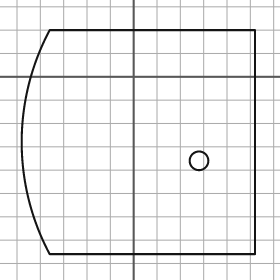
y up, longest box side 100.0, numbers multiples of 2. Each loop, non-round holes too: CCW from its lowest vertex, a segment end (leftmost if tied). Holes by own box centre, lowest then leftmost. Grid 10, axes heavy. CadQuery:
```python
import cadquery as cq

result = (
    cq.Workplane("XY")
    .moveTo(-36.0, -76.0)
    .lineTo(52.0, -76.0)
    .lineTo(52.0, 20.0)
    .lineTo(-36.0, 20.0)
    .threePointArc((-48.0, -28.0), (-36.0, -76.0))
    .close()
    .moveTo(28.0, -36.0)
    .circle(4.0)
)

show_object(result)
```